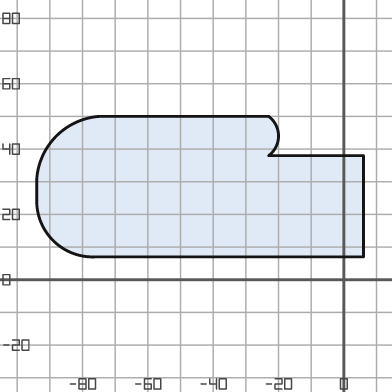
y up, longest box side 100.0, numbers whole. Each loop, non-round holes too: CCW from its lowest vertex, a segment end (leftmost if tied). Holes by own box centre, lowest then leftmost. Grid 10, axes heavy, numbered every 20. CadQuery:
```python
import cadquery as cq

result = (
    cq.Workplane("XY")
    .moveTo(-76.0, 7.0)
    .lineTo(6.0, 7.0)
    .lineTo(6.0, 38.0)
    .lineTo(-23.0, 38.0)
    .threePointArc((-20.0, 44.0), (-23.0, 50.0))
    .lineTo(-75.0, 50.0)
    .threePointArc((-88.0, 44.0), (-94.0, 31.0))
    .lineTo(-94.0, 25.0)
    .threePointArc((-89.0, 12.0), (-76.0, 7.0))
    .close()
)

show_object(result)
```